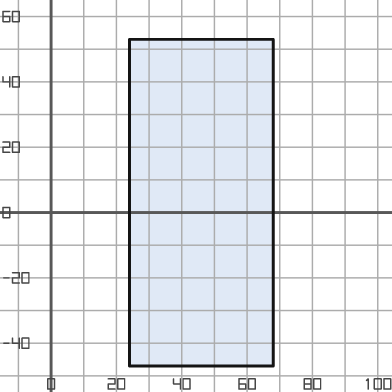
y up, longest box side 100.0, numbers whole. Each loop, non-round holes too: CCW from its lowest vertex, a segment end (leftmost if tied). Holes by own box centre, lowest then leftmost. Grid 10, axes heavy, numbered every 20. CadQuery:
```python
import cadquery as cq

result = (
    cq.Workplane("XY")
    .moveTo(24.0, -47.0)
    .lineTo(68.0, -47.0)
    .lineTo(68.0, 53.0)
    .lineTo(24.0, 53.0)
    .close()
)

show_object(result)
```